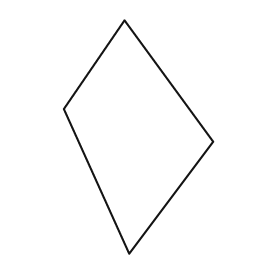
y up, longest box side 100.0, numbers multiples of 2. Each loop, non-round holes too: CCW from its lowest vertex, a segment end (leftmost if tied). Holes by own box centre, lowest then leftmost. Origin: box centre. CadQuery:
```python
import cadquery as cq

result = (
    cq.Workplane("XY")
    .moveTo(-4.0, -50.0)
    .lineTo(32.0, -2.0)
    .lineTo(-6.0, 50.0)
    .lineTo(-32.0, 12.0)
    .close()
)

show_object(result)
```